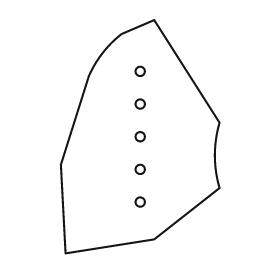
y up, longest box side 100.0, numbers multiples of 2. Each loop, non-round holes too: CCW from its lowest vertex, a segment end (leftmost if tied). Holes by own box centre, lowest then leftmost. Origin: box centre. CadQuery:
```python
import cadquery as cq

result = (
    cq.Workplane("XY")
    .moveTo(-32.0, -50.0)
    .lineTo(6.0, -44.0)
    .lineTo(34.0, -22.0)
    .threePointArc((32.0, -8.0), (34.0, 6.0))
    .lineTo(6.0, 50.0)
    .lineTo(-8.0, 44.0)
    .threePointArc((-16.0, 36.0), (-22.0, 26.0))
    .lineTo(-34.0, -12.0)
    .close()
    .moveTo(0.0, -28.0)
    .circle(2.0)
    .moveTo(0.0, -14.0)
    .circle(2.0)
    .moveTo(0.0, 0.0)
    .circle(2.0)
    .moveTo(0.0, 14.0)
    .circle(2.0)
    .moveTo(0.0, 28.0)
    .circle(2.0)
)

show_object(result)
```